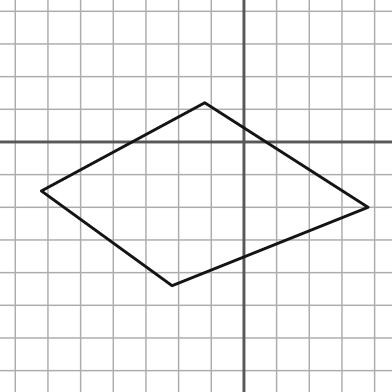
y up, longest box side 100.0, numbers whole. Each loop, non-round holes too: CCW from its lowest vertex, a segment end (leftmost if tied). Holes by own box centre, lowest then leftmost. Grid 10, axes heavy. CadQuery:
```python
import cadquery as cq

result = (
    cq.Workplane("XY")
    .moveTo(-22.0, -44.0)
    .lineTo(38.0, -20.0)
    .lineTo(-12.0, 12.0)
    .lineTo(-62.0, -15.0)
    .close()
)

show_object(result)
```